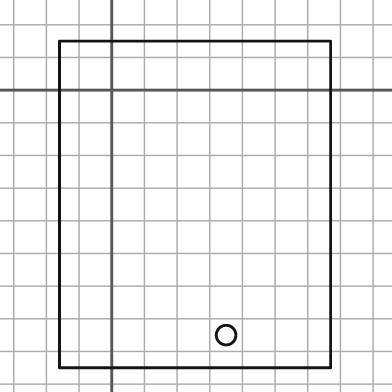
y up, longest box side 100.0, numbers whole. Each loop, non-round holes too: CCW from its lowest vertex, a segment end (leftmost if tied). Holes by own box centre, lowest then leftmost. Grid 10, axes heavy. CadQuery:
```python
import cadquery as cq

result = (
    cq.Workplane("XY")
    .moveTo(-16.0, -85.0)
    .lineTo(67.0, -85.0)
    .lineTo(67.0, 15.0)
    .lineTo(-16.0, 15.0)
    .close()
    .moveTo(35.0, -75.0)
    .circle(3.0)
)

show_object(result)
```